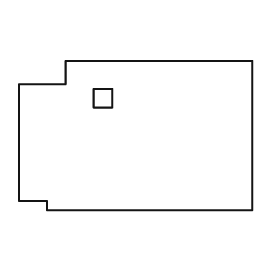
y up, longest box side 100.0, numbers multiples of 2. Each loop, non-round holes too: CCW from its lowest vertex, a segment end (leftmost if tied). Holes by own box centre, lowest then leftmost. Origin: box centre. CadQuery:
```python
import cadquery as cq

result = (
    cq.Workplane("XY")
    .moveTo(-38.0, -32.0)
    .lineTo(50.0, -32.0)
    .lineTo(50.0, 32.0)
    .lineTo(-30.0, 32.0)
    .lineTo(-30.0, 22.0)
    .lineTo(-50.0, 22.0)
    .lineTo(-50.0, -28.0)
    .lineTo(-38.0, -28.0)
    .close()
    .moveTo(-18.0, 12.0)
    .lineTo(-10.0, 12.0)
    .lineTo(-10.0, 20.0)
    .lineTo(-18.0, 20.0)
    .close()
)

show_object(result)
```